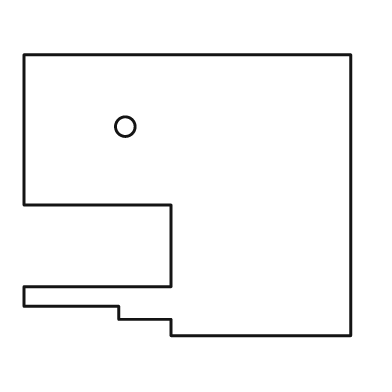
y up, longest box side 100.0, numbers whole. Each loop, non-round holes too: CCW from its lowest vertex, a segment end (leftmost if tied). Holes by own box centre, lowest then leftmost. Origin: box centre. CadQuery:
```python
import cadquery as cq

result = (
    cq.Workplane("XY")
    .moveTo(-5.0, -43.0)
    .lineTo(50.0, -43.0)
    .lineTo(50.0, 43.0)
    .lineTo(-50.0, 43.0)
    .lineTo(-50.0, -3.0)
    .lineTo(-5.0, -3.0)
    .lineTo(-5.0, -28.0)
    .lineTo(-50.0, -28.0)
    .lineTo(-50.0, -34.0)
    .lineTo(-21.0, -34.0)
    .lineTo(-21.0, -38.0)
    .lineTo(-5.0, -38.0)
    .close()
    .moveTo(-19.0, 21.0)
    .circle(3.0)
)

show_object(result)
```